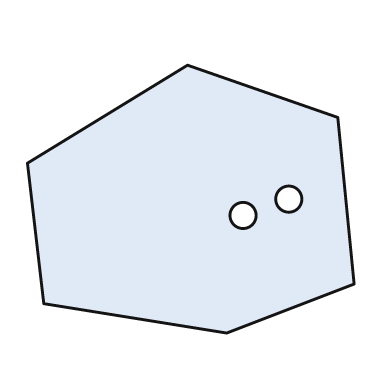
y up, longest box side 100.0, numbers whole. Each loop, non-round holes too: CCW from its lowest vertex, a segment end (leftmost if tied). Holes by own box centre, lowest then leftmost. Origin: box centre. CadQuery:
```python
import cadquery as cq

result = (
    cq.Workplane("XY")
    .moveTo(11.0, -41.0)
    .lineTo(50.0, -26.0)
    .lineTo(45.0, 25.0)
    .lineTo(-1.0, 41.0)
    .lineTo(-50.0, 11.0)
    .lineTo(-45.0, -32.0)
    .close()
    .moveTo(16.0, -5.0)
    .circle(4.0)
    .moveTo(30.0, 0.0)
    .circle(4.0)
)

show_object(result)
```